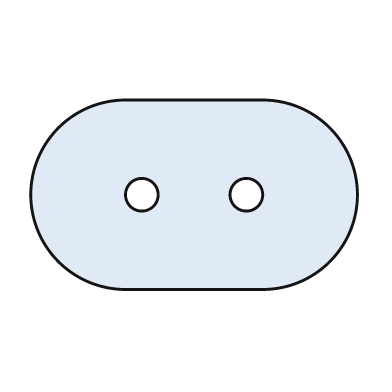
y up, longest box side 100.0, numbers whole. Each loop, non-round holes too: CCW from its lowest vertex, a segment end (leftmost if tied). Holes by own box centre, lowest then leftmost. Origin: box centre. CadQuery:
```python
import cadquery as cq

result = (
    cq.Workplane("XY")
    .moveTo(-21.0, -29.0)
    .lineTo(21.0, -29.0)
    .threePointArc((50.0, 0.0), (21.0, 29.0))
    .lineTo(-21.0, 29.0)
    .threePointArc((-50.0, 0.0), (-21.0, -29.0))
    .close()
    .moveTo(-16.0, 0.0)
    .circle(5.0)
    .moveTo(16.0, 0.0)
    .circle(5.0)
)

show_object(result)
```